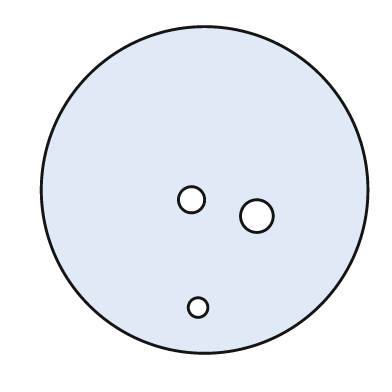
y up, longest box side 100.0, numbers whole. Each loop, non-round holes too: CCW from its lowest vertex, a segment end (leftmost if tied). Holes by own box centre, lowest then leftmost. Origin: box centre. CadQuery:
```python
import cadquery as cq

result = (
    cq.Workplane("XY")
    .moveTo(0.0, 0.0)
    .circle(50.0)
    .moveTo(-2.0, -36.0)
    .circle(3.0)
    .moveTo(16.0, -8.0)
    .circle(5.0)
    .moveTo(-4.0, -3.0)
    .circle(4.0)
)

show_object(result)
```